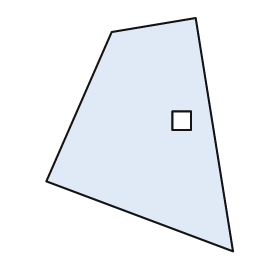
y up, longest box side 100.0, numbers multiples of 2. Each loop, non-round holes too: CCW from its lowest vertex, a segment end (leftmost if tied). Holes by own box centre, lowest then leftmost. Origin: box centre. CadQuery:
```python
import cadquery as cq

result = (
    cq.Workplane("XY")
    .moveTo(40.0, -50.0)
    .lineTo(24.0, 50.0)
    .lineTo(-12.0, 44.0)
    .lineTo(-40.0, -20.0)
    .close()
    .moveTo(14.0, 2.0)
    .lineTo(22.0, 2.0)
    .lineTo(22.0, 10.0)
    .lineTo(14.0, 10.0)
    .close()
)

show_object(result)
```